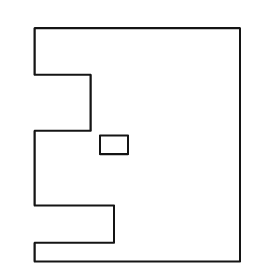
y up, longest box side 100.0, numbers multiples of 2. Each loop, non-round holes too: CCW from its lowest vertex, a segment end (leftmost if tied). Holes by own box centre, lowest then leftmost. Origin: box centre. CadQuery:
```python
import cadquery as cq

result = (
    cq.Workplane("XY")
    .moveTo(-44.0, -50.0)
    .lineTo(44.0, -50.0)
    .lineTo(44.0, 50.0)
    .lineTo(-44.0, 50.0)
    .lineTo(-44.0, 30.0)
    .lineTo(-20.0, 30.0)
    .lineTo(-20.0, 6.0)
    .lineTo(-44.0, 6.0)
    .lineTo(-44.0, -26.0)
    .lineTo(-10.0, -26.0)
    .lineTo(-10.0, -42.0)
    .lineTo(-44.0, -42.0)
    .close()
    .moveTo(-16.0, -4.0)
    .lineTo(-4.0, -4.0)
    .lineTo(-4.0, 4.0)
    .lineTo(-16.0, 4.0)
    .close()
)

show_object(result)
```